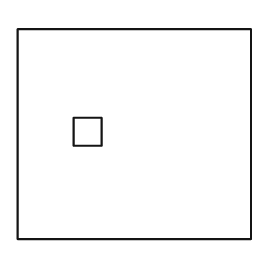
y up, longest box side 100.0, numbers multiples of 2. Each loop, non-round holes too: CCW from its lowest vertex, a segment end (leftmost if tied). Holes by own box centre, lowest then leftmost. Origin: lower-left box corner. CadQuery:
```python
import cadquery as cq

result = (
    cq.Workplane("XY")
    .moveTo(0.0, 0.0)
    .lineTo(100.0, 0.0)
    .lineTo(100.0, 90.0)
    .lineTo(0.0, 90.0)
    .close()
    .moveTo(24.0, 40.0)
    .lineTo(36.0, 40.0)
    .lineTo(36.0, 52.0)
    .lineTo(24.0, 52.0)
    .close()
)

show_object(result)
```